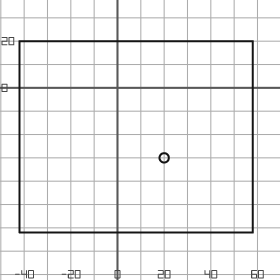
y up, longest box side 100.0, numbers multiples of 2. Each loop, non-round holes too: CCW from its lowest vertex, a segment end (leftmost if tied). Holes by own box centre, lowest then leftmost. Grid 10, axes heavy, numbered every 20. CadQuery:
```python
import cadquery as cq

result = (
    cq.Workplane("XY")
    .moveTo(-42.0, -62.0)
    .lineTo(58.0, -62.0)
    .lineTo(58.0, 20.0)
    .lineTo(-42.0, 20.0)
    .close()
    .moveTo(20.0, -30.0)
    .circle(2.0)
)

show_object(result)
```